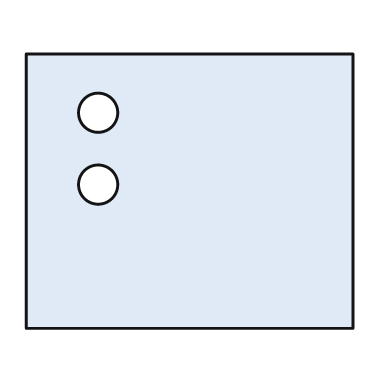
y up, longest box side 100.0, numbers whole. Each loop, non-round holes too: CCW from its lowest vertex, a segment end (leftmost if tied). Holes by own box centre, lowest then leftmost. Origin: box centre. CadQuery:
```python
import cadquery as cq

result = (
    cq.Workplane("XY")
    .moveTo(-50.0, -42.0)
    .lineTo(50.0, -42.0)
    .lineTo(50.0, 42.0)
    .lineTo(-50.0, 42.0)
    .close()
    .moveTo(-28.0, 2.0)
    .circle(6.0)
    .moveTo(-28.0, 24.0)
    .circle(6.0)
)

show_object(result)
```